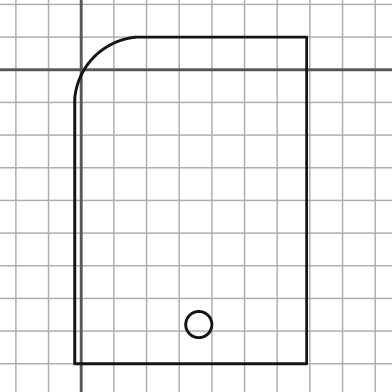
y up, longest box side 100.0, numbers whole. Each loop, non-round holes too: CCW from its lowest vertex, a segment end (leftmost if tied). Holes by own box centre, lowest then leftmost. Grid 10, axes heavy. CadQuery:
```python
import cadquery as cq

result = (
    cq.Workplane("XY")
    .moveTo(-2.0, -90.0)
    .lineTo(69.0, -90.0)
    .lineTo(69.0, 10.0)
    .lineTo(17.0, 10.0)
    .threePointArc((4.0, 4.0), (-2.0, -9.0))
    .close()
    .moveTo(36.0, -78.0)
    .circle(4.0)
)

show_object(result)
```